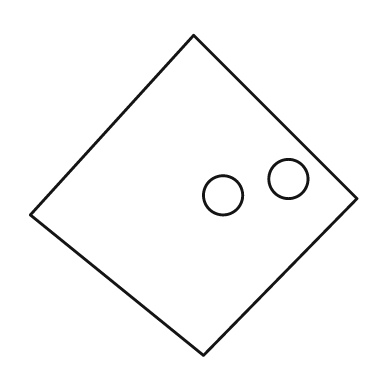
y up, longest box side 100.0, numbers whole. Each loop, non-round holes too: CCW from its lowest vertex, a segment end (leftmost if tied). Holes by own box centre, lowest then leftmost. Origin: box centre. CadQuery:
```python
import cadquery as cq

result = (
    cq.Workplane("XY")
    .moveTo(3.0, -49.0)
    .lineTo(50.0, -1.0)
    .lineTo(0.0, 49.0)
    .lineTo(-50.0, -6.0)
    .close()
    .moveTo(9.0, 0.0)
    .circle(6.0)
    .moveTo(29.0, 5.0)
    .circle(6.0)
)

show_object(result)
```